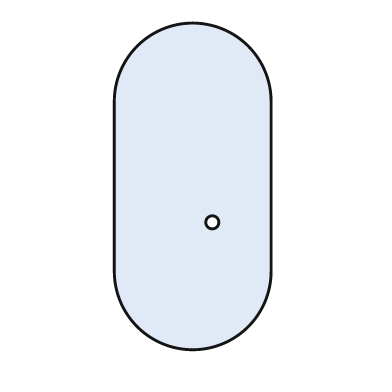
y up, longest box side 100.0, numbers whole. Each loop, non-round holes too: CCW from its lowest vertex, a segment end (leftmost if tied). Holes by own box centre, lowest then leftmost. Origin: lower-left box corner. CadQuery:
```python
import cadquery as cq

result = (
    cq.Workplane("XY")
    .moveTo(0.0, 24.0)
    .threePointArc((24.0, 0.0), (48.0, 24.0))
    .lineTo(48.0, 76.0)
    .threePointArc((24.0, 100.0), (0.0, 76.0))
    .close()
    .moveTo(30.0, 39.0)
    .circle(2.0)
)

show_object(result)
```